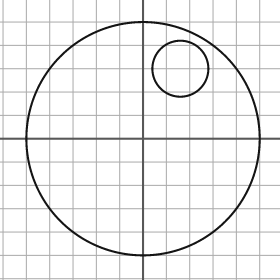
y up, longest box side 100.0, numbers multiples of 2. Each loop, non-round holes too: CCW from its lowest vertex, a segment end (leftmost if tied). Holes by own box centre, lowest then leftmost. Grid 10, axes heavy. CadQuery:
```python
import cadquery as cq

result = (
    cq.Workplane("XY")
    .moveTo(0.0, 0.0)
    .circle(50.0)
    .moveTo(16.0, 30.0)
    .circle(12.0)
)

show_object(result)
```